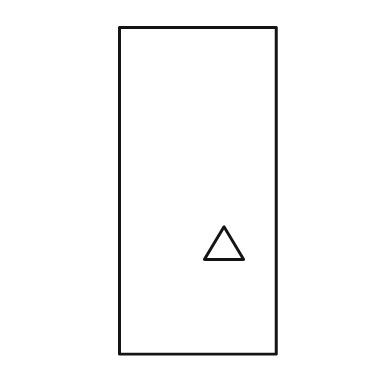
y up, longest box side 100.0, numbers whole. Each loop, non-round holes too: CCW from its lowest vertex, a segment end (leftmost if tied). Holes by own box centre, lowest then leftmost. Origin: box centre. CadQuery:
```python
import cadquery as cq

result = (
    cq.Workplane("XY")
    .moveTo(-24.0, -50.0)
    .lineTo(24.0, -50.0)
    .lineTo(24.0, 50.0)
    .lineTo(-24.0, 50.0)
    .close()
    .moveTo(2.0, -21.0)
    .lineTo(14.0, -21.0)
    .lineTo(8.0, -11.0)
    .close()
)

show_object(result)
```